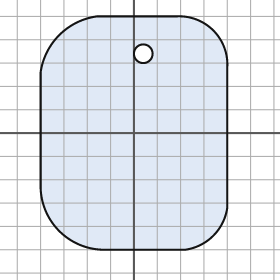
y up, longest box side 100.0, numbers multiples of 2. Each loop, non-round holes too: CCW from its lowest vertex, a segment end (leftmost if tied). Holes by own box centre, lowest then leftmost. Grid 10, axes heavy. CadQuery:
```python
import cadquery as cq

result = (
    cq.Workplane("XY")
    .moveTo(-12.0, -50.0)
    .lineTo(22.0, -50.0)
    .threePointArc((34.0, -44.0), (40.0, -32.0))
    .lineTo(40.0, 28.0)
    .threePointArc((34.0, 44.0), (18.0, 50.0))
    .lineTo(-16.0, 50.0)
    .threePointArc((-32.0, 42.0), (-40.0, 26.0))
    .lineTo(-40.0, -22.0)
    .threePointArc((-32.0, -42.0), (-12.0, -50.0))
    .close()
    .moveTo(4.0, 34.0)
    .circle(4.0)
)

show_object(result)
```